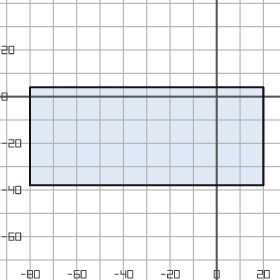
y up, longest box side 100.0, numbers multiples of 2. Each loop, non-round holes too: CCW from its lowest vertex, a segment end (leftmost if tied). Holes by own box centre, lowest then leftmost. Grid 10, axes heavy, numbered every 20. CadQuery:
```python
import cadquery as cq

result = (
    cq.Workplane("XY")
    .moveTo(-80.0, -38.0)
    .lineTo(20.0, -38.0)
    .lineTo(20.0, 4.0)
    .lineTo(-80.0, 4.0)
    .close()
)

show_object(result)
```